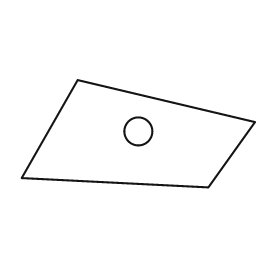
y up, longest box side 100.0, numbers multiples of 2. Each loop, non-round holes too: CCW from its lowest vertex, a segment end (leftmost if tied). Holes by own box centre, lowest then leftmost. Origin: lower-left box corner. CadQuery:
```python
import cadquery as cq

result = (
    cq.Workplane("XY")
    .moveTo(80.0, 0.0)
    .lineTo(100.0, 28.0)
    .lineTo(24.0, 46.0)
    .lineTo(0.0, 4.0)
    .close()
    .moveTo(50.0, 24.0)
    .circle(6.0)
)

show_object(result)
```